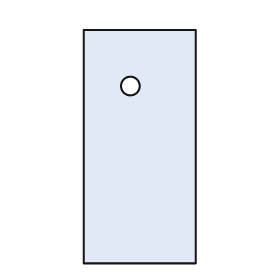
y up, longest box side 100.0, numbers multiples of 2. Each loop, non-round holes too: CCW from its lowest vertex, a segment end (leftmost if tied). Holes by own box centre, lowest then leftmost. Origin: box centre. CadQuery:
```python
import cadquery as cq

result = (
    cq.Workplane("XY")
    .moveTo(-24.0, -50.0)
    .lineTo(24.0, -50.0)
    .lineTo(24.0, 50.0)
    .lineTo(-24.0, 50.0)
    .close()
    .moveTo(-4.0, 26.0)
    .circle(4.0)
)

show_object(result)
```